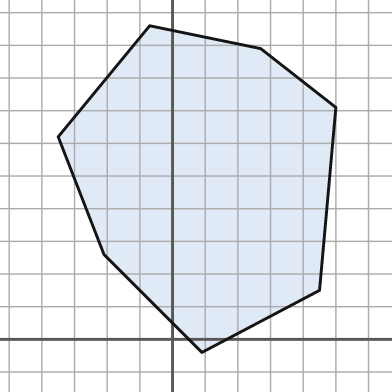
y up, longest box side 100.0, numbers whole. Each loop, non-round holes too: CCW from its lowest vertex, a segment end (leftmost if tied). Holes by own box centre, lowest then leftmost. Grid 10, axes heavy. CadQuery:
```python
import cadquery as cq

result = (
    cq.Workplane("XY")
    .moveTo(9.0, -4.0)
    .lineTo(45.0, 15.0)
    .lineTo(50.0, 71.0)
    .lineTo(27.0, 89.0)
    .lineTo(-7.0, 96.0)
    .lineTo(-35.0, 62.0)
    .lineTo(-21.0, 26.0)
    .close()
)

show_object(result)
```